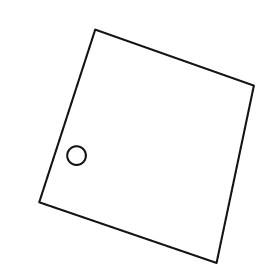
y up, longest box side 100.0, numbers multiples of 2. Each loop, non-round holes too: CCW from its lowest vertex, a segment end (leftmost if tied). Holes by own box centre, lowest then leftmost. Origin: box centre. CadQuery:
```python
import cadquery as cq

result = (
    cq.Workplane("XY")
    .moveTo(30.0, -50.0)
    .lineTo(46.0, 26.0)
    .lineTo(-22.0, 50.0)
    .lineTo(-46.0, -24.0)
    .close()
    .moveTo(-30.0, -4.0)
    .circle(4.0)
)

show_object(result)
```